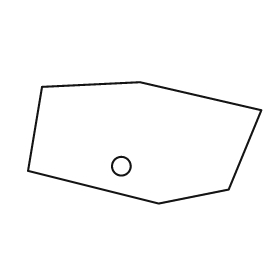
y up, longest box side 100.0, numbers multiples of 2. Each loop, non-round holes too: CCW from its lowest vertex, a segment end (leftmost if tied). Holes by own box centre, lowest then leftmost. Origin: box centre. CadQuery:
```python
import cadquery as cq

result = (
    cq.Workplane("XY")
    .moveTo(6.0, -26.0)
    .lineTo(36.0, -20.0)
    .lineTo(50.0, 14.0)
    .lineTo(-2.0, 26.0)
    .lineTo(-44.0, 24.0)
    .lineTo(-50.0, -12.0)
    .close()
    .moveTo(-10.0, -10.0)
    .circle(4.0)
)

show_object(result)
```